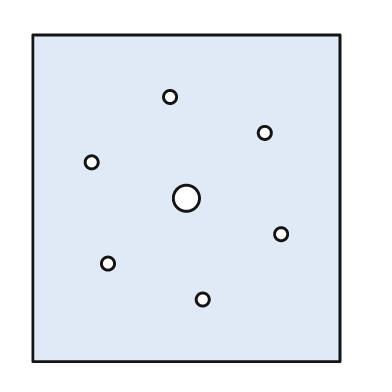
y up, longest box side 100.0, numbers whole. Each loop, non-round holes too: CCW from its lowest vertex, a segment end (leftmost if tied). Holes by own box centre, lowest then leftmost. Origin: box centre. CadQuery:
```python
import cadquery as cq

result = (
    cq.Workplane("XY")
    .moveTo(-47.0, -50.0)
    .lineTo(47.0, -50.0)
    .lineTo(47.0, 50.0)
    .lineTo(-47.0, 50.0)
    .close()
    .moveTo(5.0, -31.0)
    .circle(2.0)
    .moveTo(-24.0, -20.0)
    .circle(2.0)
    .moveTo(29.0, -11.0)
    .circle(2.0)
    .moveTo(0.0, 0.0)
    .circle(4.0)
    .moveTo(-29.0, 11.0)
    .circle(2.0)
    .moveTo(24.0, 20.0)
    .circle(2.0)
    .moveTo(-5.0, 31.0)
    .circle(2.0)
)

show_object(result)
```